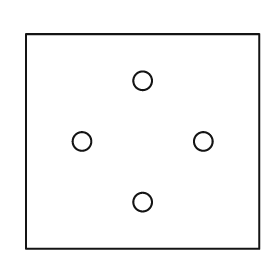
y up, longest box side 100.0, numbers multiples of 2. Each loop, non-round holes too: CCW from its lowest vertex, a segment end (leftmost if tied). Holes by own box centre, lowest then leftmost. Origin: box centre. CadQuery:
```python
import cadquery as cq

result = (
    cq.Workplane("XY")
    .moveTo(-50.0, -46.0)
    .lineTo(50.0, -46.0)
    .lineTo(50.0, 46.0)
    .lineTo(-50.0, 46.0)
    .close()
    .moveTo(0.0, -26.0)
    .circle(4.0)
    .moveTo(-26.0, 0.0)
    .circle(4.0)
    .moveTo(26.0, 0.0)
    .circle(4.0)
    .moveTo(0.0, 26.0)
    .circle(4.0)
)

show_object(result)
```